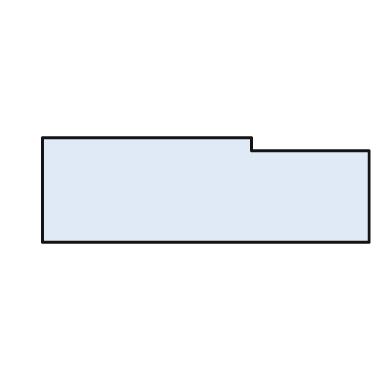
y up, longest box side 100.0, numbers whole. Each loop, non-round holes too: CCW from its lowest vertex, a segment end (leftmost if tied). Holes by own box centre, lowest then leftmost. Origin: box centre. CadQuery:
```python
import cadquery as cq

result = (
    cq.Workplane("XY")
    .moveTo(-50.0, -16.0)
    .lineTo(50.0, -16.0)
    .lineTo(50.0, 12.0)
    .lineTo(14.0, 12.0)
    .lineTo(14.0, 16.0)
    .lineTo(-50.0, 16.0)
    .close()
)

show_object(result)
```